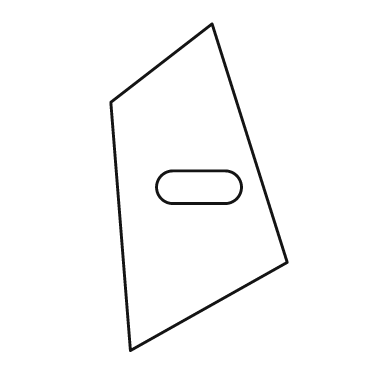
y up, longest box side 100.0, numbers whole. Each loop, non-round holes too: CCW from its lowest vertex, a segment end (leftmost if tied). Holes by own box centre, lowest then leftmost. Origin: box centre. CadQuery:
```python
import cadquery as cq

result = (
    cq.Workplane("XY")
    .moveTo(-21.0, -50.0)
    .lineTo(27.0, -23.0)
    .lineTo(4.0, 50.0)
    .lineTo(-27.0, 26.0)
    .close()
    .moveTo(-8.0, -5.0)
    .lineTo(8.0, -5.0)
    .threePointArc((13.0, 0.0), (8.0, 5.0))
    .lineTo(-8.0, 5.0)
    .threePointArc((-13.0, 0.0), (-8.0, -5.0))
    .close()
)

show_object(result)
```